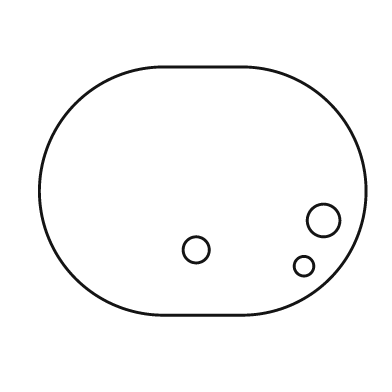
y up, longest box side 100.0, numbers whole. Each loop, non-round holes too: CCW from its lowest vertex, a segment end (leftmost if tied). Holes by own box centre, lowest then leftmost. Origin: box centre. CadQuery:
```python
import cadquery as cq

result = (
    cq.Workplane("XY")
    .moveTo(-12.0, -38.0)
    .lineTo(12.0, -38.0)
    .threePointArc((50.0, 0.0), (12.0, 38.0))
    .lineTo(-12.0, 38.0)
    .threePointArc((-50.0, 0.0), (-12.0, -38.0))
    .close()
    .moveTo(31.0, -23.0)
    .circle(3.0)
    .moveTo(-2.0, -18.0)
    .circle(4.0)
    .moveTo(37.0, -9.0)
    .circle(5.0)
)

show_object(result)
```